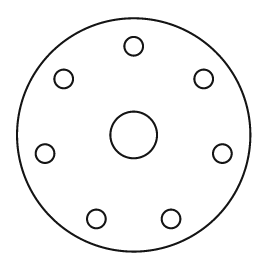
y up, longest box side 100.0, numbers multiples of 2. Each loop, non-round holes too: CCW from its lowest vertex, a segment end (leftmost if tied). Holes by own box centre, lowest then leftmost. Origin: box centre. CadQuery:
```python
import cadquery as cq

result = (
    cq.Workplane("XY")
    .moveTo(0.0, 0.0)
    .circle(50.0)
    .moveTo(-16.0, -36.0)
    .circle(4.0)
    .moveTo(16.0, -36.0)
    .circle(4.0)
    .moveTo(-38.0, -8.0)
    .circle(4.0)
    .moveTo(38.0, -8.0)
    .circle(4.0)
    .moveTo(0.0, 0.0)
    .circle(10.0)
    .moveTo(-30.0, 24.0)
    .circle(4.0)
    .moveTo(30.0, 24.0)
    .circle(4.0)
    .moveTo(0.0, 38.0)
    .circle(4.0)
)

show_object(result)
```